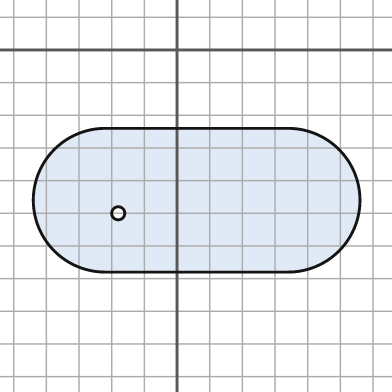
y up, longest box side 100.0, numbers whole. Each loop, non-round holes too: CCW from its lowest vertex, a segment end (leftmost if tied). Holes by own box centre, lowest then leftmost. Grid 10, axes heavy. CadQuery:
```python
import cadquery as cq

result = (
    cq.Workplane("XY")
    .moveTo(-22.0, -68.0)
    .lineTo(34.0, -68.0)
    .threePointArc((56.0, -46.0), (34.0, -24.0))
    .lineTo(-22.0, -24.0)
    .threePointArc((-44.0, -46.0), (-22.0, -68.0))
    .close()
    .moveTo(-18.0, -50.0)
    .circle(2.0)
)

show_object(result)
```